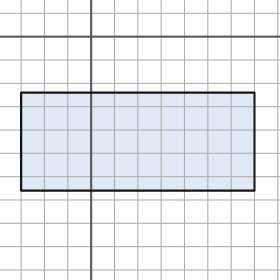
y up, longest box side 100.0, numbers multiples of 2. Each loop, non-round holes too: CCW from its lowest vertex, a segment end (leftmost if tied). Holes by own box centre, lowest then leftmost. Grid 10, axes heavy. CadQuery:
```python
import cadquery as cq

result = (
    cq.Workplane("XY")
    .moveTo(-30.0, -66.0)
    .lineTo(70.0, -66.0)
    .lineTo(70.0, -24.0)
    .lineTo(-30.0, -24.0)
    .close()
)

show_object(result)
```